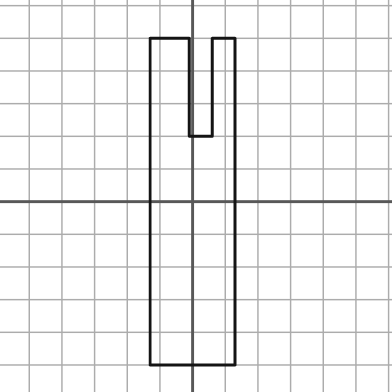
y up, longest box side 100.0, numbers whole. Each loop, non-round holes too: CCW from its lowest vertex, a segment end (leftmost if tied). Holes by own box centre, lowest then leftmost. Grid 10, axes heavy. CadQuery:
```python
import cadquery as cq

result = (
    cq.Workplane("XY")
    .moveTo(-13.0, -50.0)
    .lineTo(13.0, -50.0)
    .lineTo(13.0, 50.0)
    .lineTo(6.0, 50.0)
    .lineTo(6.0, 20.0)
    .lineTo(-1.0, 20.0)
    .lineTo(-1.0, 50.0)
    .lineTo(-13.0, 50.0)
    .close()
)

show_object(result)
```